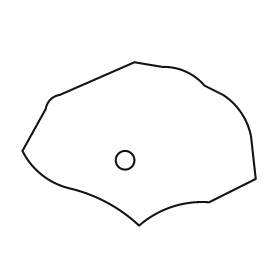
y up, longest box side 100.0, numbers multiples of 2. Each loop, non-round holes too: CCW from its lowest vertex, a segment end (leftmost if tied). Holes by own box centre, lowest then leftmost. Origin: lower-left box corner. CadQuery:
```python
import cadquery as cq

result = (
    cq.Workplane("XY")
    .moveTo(50.0, 0.0)
    .threePointArc((64.0, 8.0), (80.0, 10.0))
    .lineTo(100.0, 20.0)
    .lineTo(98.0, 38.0)
    .threePointArc((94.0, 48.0), (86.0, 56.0))
    .lineTo(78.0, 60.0)
    .threePointArc((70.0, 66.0), (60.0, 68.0))
    .lineTo(48.0, 70.0)
    .lineTo(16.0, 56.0)
    .threePointArc((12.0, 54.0), (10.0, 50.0))
    .lineTo(0.0, 32.0)
    .threePointArc((8.0, 22.0), (20.0, 16.0))
    .threePointArc((36.0, 10.0), (50.0, 0.0))
    .close()
    .moveTo(44.0, 28.0)
    .circle(4.0)
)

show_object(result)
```